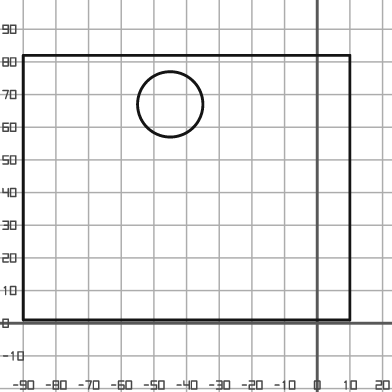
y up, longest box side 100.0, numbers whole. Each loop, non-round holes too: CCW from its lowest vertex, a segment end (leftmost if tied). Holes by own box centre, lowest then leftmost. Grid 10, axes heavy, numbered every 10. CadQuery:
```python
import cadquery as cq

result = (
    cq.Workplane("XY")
    .moveTo(-90.0, 1.0)
    .lineTo(10.0, 1.0)
    .lineTo(10.0, 82.0)
    .lineTo(-90.0, 82.0)
    .close()
    .moveTo(-45.0, 67.0)
    .circle(10.0)
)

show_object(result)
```